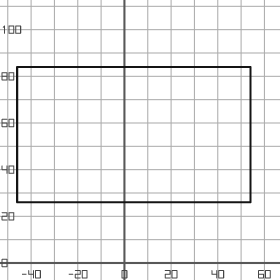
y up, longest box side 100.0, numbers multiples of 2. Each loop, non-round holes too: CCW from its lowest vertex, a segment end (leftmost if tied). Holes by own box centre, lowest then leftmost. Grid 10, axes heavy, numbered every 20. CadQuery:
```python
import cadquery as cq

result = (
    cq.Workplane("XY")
    .moveTo(-46.0, 26.0)
    .lineTo(54.0, 26.0)
    .lineTo(54.0, 84.0)
    .lineTo(-46.0, 84.0)
    .close()
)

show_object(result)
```